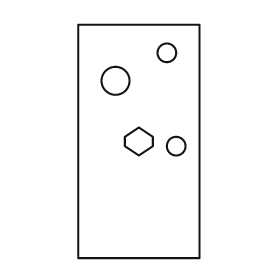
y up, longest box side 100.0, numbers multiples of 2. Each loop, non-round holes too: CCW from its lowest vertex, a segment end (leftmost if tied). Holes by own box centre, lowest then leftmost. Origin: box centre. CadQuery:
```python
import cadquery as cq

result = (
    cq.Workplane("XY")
    .moveTo(-26.0, -50.0)
    .lineTo(26.0, -50.0)
    .lineTo(26.0, 50.0)
    .lineTo(-26.0, 50.0)
    .close()
    .moveTo(16.0, -2.0)
    .circle(4.0)
    .moveTo(0.0, -6.0)
    .lineTo(6.0, -2.0)
    .lineTo(6.0, 2.0)
    .lineTo(0.0, 6.0)
    .lineTo(-6.0, 2.0)
    .lineTo(-6.0, -2.0)
    .close()
    .moveTo(-10.0, 26.0)
    .circle(6.0)
    .moveTo(12.0, 38.0)
    .circle(4.0)
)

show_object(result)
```